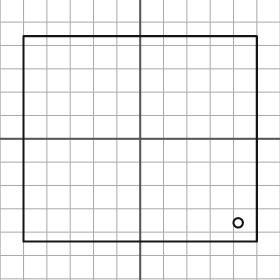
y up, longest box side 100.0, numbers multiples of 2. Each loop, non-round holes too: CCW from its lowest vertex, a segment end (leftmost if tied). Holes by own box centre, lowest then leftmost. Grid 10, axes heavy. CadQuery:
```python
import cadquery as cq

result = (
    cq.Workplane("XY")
    .moveTo(-50.0, -44.0)
    .lineTo(50.0, -44.0)
    .lineTo(50.0, 44.0)
    .lineTo(-50.0, 44.0)
    .close()
    .moveTo(42.0, -36.0)
    .circle(2.0)
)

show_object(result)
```